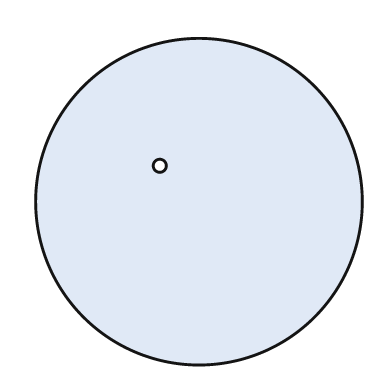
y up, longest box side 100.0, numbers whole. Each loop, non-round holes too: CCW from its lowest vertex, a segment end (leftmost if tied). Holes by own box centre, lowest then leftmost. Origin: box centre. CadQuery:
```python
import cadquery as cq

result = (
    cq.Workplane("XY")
    .moveTo(0.0, 0.0)
    .circle(50.0)
    .moveTo(-12.0, 11.0)
    .circle(2.0)
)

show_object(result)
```